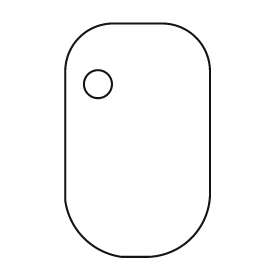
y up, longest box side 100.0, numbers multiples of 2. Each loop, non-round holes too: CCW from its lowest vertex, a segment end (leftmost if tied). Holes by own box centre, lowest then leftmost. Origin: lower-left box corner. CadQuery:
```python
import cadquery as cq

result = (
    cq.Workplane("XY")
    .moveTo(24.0, 0.0)
    .lineTo(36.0, 0.0)
    .threePointArc((54.0, 8.0), (62.0, 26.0))
    .lineTo(62.0, 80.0)
    .threePointArc((56.0, 94.0), (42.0, 100.0))
    .lineTo(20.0, 100.0)
    .threePointArc((6.0, 94.0), (0.0, 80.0))
    .lineTo(0.0, 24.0)
    .threePointArc((8.0, 8.0), (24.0, 0.0))
    .close()
    .moveTo(14.0, 74.0)
    .circle(6.0)
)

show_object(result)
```